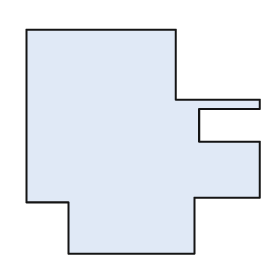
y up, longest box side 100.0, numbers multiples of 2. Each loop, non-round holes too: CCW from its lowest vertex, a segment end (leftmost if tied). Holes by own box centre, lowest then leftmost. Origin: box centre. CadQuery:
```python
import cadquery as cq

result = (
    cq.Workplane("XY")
    .moveTo(-32.0, -48.0)
    .lineTo(22.0, -48.0)
    .lineTo(22.0, -24.0)
    .lineTo(50.0, -24.0)
    .lineTo(50.0, 0.0)
    .lineTo(24.0, 0.0)
    .lineTo(24.0, 14.0)
    .lineTo(50.0, 14.0)
    .lineTo(50.0, 18.0)
    .lineTo(14.0, 18.0)
    .lineTo(14.0, 48.0)
    .lineTo(-50.0, 48.0)
    .lineTo(-50.0, -26.0)
    .lineTo(-32.0, -26.0)
    .close()
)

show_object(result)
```